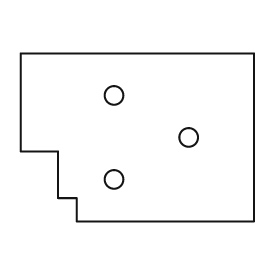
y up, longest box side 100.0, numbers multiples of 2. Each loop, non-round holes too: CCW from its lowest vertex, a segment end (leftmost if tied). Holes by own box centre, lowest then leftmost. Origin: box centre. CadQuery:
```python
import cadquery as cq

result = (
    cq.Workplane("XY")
    .moveTo(-26.0, -36.0)
    .lineTo(50.0, -36.0)
    .lineTo(50.0, 36.0)
    .lineTo(-50.0, 36.0)
    .lineTo(-50.0, -6.0)
    .lineTo(-34.0, -6.0)
    .lineTo(-34.0, -26.0)
    .lineTo(-26.0, -26.0)
    .close()
    .moveTo(-10.0, -18.0)
    .circle(4.0)
    .moveTo(22.0, 0.0)
    .circle(4.0)
    .moveTo(-10.0, 18.0)
    .circle(4.0)
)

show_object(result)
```